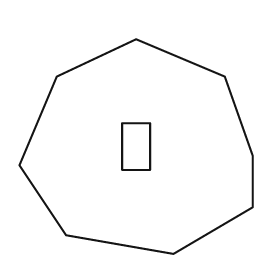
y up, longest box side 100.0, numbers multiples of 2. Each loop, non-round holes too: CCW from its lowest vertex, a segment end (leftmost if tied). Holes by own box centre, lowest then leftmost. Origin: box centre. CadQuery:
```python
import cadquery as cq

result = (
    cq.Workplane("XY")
    .moveTo(16.0, -46.0)
    .lineTo(50.0, -26.0)
    .lineTo(50.0, -4.0)
    .lineTo(38.0, 30.0)
    .lineTo(0.0, 46.0)
    .lineTo(-34.0, 30.0)
    .lineTo(-50.0, -8.0)
    .lineTo(-30.0, -38.0)
    .close()
    .moveTo(-6.0, -10.0)
    .lineTo(6.0, -10.0)
    .lineTo(6.0, 10.0)
    .lineTo(-6.0, 10.0)
    .close()
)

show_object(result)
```